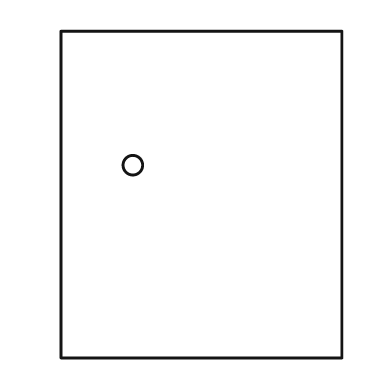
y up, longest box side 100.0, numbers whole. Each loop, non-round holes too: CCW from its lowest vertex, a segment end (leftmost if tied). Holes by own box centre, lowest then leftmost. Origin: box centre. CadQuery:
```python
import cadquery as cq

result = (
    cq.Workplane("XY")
    .moveTo(-43.0, -50.0)
    .lineTo(43.0, -50.0)
    .lineTo(43.0, 50.0)
    .lineTo(-43.0, 50.0)
    .close()
    .moveTo(-21.0, 9.0)
    .circle(3.0)
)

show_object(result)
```